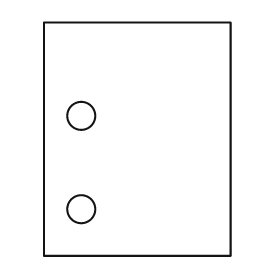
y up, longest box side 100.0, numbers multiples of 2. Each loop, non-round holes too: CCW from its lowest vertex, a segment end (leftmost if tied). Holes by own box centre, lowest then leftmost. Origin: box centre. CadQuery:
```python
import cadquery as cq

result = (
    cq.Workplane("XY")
    .moveTo(-40.0, -50.0)
    .lineTo(40.0, -50.0)
    .lineTo(40.0, 50.0)
    .lineTo(-40.0, 50.0)
    .close()
    .moveTo(-24.0, -30.0)
    .circle(6.0)
    .moveTo(-24.0, 10.0)
    .circle(6.0)
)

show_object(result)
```